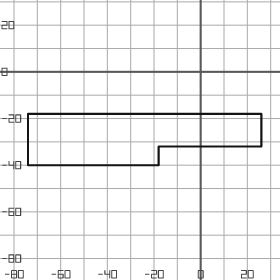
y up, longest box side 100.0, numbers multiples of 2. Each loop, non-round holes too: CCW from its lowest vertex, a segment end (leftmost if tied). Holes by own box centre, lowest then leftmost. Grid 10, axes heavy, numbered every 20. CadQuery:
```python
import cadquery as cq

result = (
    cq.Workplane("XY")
    .moveTo(-74.0, -40.0)
    .lineTo(-18.0, -40.0)
    .lineTo(-18.0, -32.0)
    .lineTo(26.0, -32.0)
    .lineTo(26.0, -18.0)
    .lineTo(-74.0, -18.0)
    .close()
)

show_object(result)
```